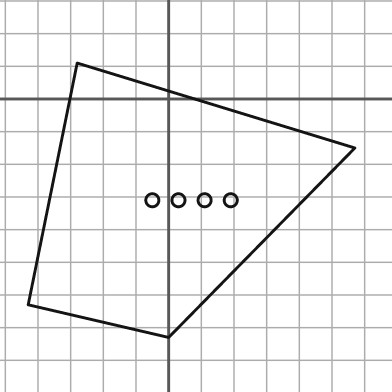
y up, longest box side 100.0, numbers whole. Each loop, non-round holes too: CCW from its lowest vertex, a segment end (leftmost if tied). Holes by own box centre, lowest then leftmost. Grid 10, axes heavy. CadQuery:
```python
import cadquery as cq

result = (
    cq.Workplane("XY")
    .moveTo(0.0, -73.0)
    .lineTo(57.0, -15.0)
    .lineTo(-28.0, 11.0)
    .lineTo(-43.0, -63.0)
    .close()
    .moveTo(-5.0, -31.0)
    .circle(2.0)
    .moveTo(3.0, -31.0)
    .circle(2.0)
    .moveTo(11.0, -31.0)
    .circle(2.0)
    .moveTo(19.0, -31.0)
    .circle(2.0)
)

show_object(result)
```